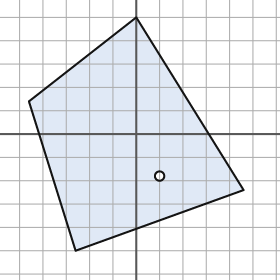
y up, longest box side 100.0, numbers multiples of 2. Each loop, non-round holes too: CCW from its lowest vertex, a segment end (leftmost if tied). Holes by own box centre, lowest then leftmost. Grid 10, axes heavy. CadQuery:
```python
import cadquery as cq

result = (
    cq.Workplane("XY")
    .moveTo(-26.0, -50.0)
    .lineTo(46.0, -24.0)
    .lineTo(0.0, 50.0)
    .lineTo(-46.0, 14.0)
    .close()
    .moveTo(10.0, -18.0)
    .circle(2.0)
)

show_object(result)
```